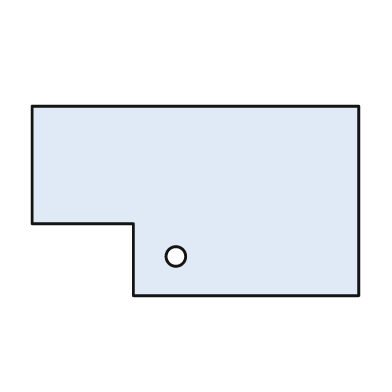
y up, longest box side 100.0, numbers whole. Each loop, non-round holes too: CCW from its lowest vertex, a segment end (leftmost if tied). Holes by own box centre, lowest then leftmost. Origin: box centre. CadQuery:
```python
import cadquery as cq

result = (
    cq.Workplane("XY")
    .moveTo(-19.0, -29.0)
    .lineTo(50.0, -29.0)
    .lineTo(50.0, 29.0)
    .lineTo(-50.0, 29.0)
    .lineTo(-50.0, -7.0)
    .lineTo(-19.0, -7.0)
    .close()
    .moveTo(-6.0, -17.0)
    .circle(3.0)
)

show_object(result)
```